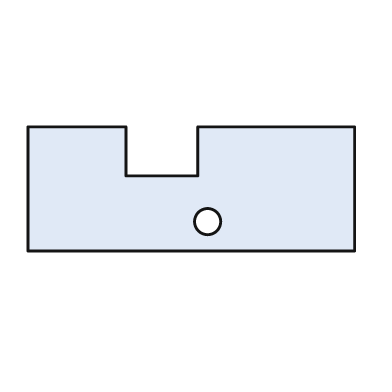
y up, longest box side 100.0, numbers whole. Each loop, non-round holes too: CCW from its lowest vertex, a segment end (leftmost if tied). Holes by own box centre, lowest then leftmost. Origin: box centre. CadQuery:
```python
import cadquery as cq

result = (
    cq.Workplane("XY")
    .moveTo(-50.0, -19.0)
    .lineTo(50.0, -19.0)
    .lineTo(50.0, 19.0)
    .lineTo(2.0, 19.0)
    .lineTo(2.0, 4.0)
    .lineTo(-20.0, 4.0)
    .lineTo(-20.0, 19.0)
    .lineTo(-50.0, 19.0)
    .close()
    .moveTo(5.0, -10.0)
    .circle(4.0)
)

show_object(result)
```